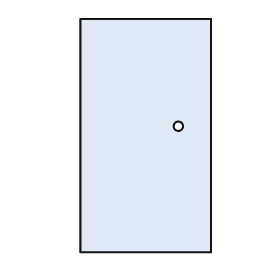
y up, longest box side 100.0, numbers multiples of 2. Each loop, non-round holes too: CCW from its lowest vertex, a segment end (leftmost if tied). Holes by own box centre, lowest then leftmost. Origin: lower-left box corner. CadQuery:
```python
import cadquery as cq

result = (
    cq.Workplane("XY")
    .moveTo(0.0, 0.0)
    .lineTo(56.0, 0.0)
    .lineTo(56.0, 100.0)
    .lineTo(0.0, 100.0)
    .close()
    .moveTo(42.0, 54.0)
    .circle(2.0)
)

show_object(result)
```